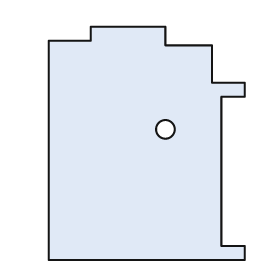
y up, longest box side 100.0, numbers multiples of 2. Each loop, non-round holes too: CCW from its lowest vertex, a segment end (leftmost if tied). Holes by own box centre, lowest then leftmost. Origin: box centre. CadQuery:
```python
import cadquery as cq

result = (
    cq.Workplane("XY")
    .moveTo(-42.0, -50.0)
    .lineTo(42.0, -50.0)
    .lineTo(42.0, -44.0)
    .lineTo(32.0, -44.0)
    .lineTo(32.0, 20.0)
    .lineTo(42.0, 20.0)
    .lineTo(42.0, 26.0)
    .lineTo(28.0, 26.0)
    .lineTo(28.0, 42.0)
    .lineTo(8.0, 42.0)
    .lineTo(8.0, 50.0)
    .lineTo(-24.0, 50.0)
    .lineTo(-24.0, 44.0)
    .lineTo(-42.0, 44.0)
    .close()
    .moveTo(8.0, 6.0)
    .circle(4.0)
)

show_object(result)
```